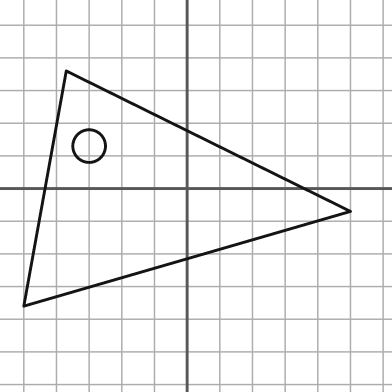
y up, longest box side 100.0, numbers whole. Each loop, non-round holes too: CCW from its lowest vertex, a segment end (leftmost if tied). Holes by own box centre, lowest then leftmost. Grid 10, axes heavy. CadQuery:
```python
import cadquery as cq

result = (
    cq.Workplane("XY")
    .moveTo(-50.0, -36.0)
    .lineTo(50.0, -7.0)
    .lineTo(-37.0, 36.0)
    .close()
    .moveTo(-30.0, 13.0)
    .circle(5.0)
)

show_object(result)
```